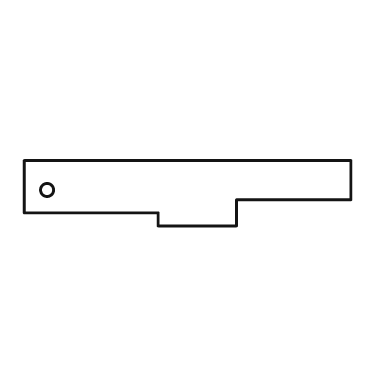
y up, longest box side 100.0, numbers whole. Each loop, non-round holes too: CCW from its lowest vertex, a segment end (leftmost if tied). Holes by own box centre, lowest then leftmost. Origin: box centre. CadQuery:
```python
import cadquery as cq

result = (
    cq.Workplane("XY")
    .moveTo(-9.0, -10.0)
    .lineTo(15.0, -10.0)
    .lineTo(15.0, -2.0)
    .lineTo(50.0, -2.0)
    .lineTo(50.0, 10.0)
    .lineTo(-50.0, 10.0)
    .lineTo(-50.0, -6.0)
    .lineTo(-9.0, -6.0)
    .close()
    .moveTo(-43.0, 1.0)
    .circle(2.0)
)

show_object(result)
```